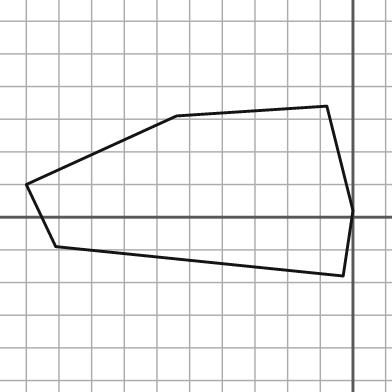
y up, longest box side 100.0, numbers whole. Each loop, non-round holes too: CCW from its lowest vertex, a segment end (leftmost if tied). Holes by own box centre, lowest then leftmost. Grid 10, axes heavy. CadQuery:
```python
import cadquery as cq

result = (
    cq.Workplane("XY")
    .moveTo(-3.0, -18.0)
    .lineTo(0.0, 2.0)
    .lineTo(-8.0, 34.0)
    .lineTo(-54.0, 31.0)
    .lineTo(-100.0, 10.0)
    .lineTo(-91.0, -9.0)
    .close()
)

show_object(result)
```